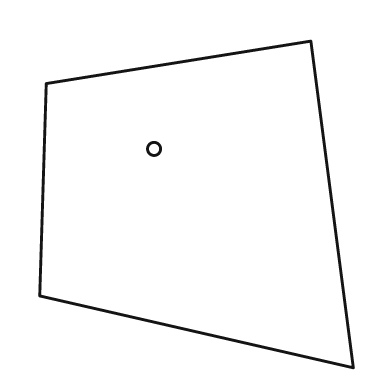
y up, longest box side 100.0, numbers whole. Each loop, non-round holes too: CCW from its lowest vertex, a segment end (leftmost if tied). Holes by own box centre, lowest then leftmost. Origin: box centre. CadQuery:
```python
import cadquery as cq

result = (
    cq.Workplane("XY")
    .moveTo(48.0, -50.0)
    .lineTo(35.0, 50.0)
    .lineTo(-46.0, 37.0)
    .lineTo(-48.0, -28.0)
    .close()
    .moveTo(-13.0, 17.0)
    .circle(2.0)
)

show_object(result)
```